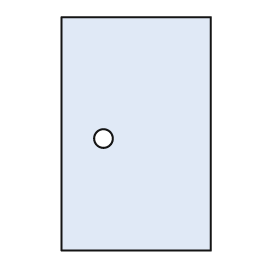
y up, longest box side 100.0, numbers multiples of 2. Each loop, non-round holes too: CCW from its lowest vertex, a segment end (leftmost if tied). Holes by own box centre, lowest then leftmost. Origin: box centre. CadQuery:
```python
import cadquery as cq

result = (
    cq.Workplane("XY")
    .moveTo(-32.0, -50.0)
    .lineTo(32.0, -50.0)
    .lineTo(32.0, 50.0)
    .lineTo(-32.0, 50.0)
    .close()
    .moveTo(-14.0, -2.0)
    .circle(4.0)
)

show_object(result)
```